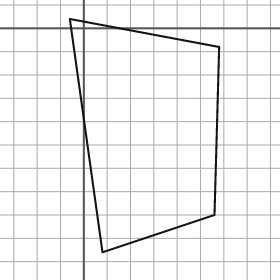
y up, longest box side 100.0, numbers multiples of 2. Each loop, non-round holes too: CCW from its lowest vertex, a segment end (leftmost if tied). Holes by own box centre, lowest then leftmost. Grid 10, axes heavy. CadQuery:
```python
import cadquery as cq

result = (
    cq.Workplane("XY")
    .moveTo(8.0, -96.0)
    .lineTo(56.0, -80.0)
    .lineTo(58.0, -8.0)
    .lineTo(-6.0, 4.0)
    .close()
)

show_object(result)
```